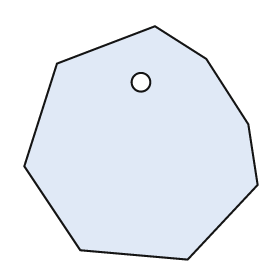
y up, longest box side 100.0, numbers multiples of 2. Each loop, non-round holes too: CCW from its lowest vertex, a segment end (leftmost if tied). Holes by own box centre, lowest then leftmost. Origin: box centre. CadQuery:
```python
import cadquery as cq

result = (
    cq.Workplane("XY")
    .moveTo(20.0, -50.0)
    .lineTo(50.0, -18.0)
    .lineTo(46.0, 8.0)
    .lineTo(28.0, 36.0)
    .lineTo(6.0, 50.0)
    .lineTo(-36.0, 34.0)
    .lineTo(-50.0, -10.0)
    .lineTo(-26.0, -46.0)
    .close()
    .moveTo(0.0, 26.0)
    .circle(4.0)
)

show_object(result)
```